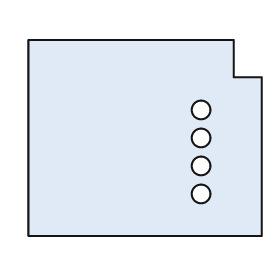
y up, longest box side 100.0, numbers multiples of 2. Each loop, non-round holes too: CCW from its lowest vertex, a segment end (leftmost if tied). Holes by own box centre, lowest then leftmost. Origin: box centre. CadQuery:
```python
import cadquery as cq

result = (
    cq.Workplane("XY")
    .moveTo(-50.0, -42.0)
    .lineTo(50.0, -42.0)
    .lineTo(50.0, 26.0)
    .lineTo(38.0, 26.0)
    .lineTo(38.0, 42.0)
    .lineTo(-50.0, 42.0)
    .close()
    .moveTo(24.0, -24.0)
    .circle(4.0)
    .moveTo(24.0, -12.0)
    .circle(4.0)
    .moveTo(24.0, 0.0)
    .circle(4.0)
    .moveTo(24.0, 12.0)
    .circle(4.0)
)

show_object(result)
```